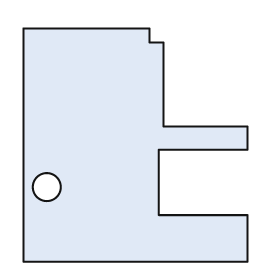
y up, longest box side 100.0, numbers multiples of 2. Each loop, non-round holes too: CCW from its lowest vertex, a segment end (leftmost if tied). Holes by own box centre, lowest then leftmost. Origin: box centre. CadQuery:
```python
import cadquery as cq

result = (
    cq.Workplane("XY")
    .moveTo(-48.0, -50.0)
    .lineTo(48.0, -50.0)
    .lineTo(48.0, -30.0)
    .lineTo(10.0, -30.0)
    .lineTo(10.0, -2.0)
    .lineTo(48.0, -2.0)
    .lineTo(48.0, 8.0)
    .lineTo(12.0, 8.0)
    .lineTo(12.0, 44.0)
    .lineTo(6.0, 44.0)
    .lineTo(6.0, 50.0)
    .lineTo(-48.0, 50.0)
    .close()
    .moveTo(-38.0, -18.0)
    .circle(6.0)
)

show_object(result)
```